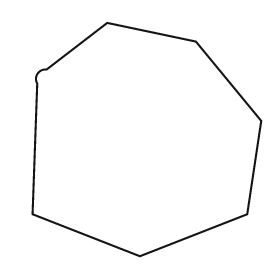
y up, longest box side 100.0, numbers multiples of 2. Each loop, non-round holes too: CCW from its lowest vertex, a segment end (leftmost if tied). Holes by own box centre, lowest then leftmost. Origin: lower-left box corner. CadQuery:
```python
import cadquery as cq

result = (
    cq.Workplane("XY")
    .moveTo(46.0, 0.0)
    .lineTo(92.0, 18.0)
    .lineTo(98.0, 58.0)
    .lineTo(70.0, 92.0)
    .lineTo(32.0, 100.0)
    .lineTo(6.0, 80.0)
    .threePointArc((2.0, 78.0), (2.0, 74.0))
    .lineTo(0.0, 18.0)
    .close()
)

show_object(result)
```